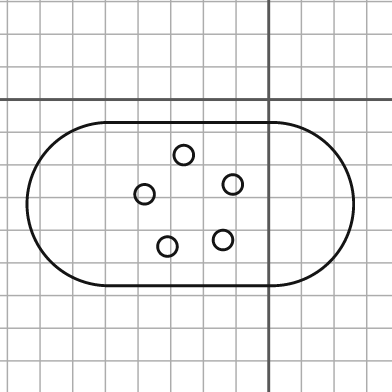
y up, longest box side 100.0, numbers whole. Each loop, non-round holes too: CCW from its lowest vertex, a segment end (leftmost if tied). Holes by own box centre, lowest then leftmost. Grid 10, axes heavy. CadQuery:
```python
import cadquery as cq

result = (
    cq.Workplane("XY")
    .moveTo(-49.0, -57.0)
    .lineTo(1.0, -57.0)
    .threePointArc((26.0, -32.0), (1.0, -7.0))
    .lineTo(-49.0, -7.0)
    .threePointArc((-74.0, -32.0), (-49.0, -57.0))
    .close()
    .moveTo(-31.0, -45.0)
    .circle(3.0)
    .moveTo(-14.0, -43.0)
    .circle(3.0)
    .moveTo(-38.0, -29.0)
    .circle(3.0)
    .moveTo(-11.0, -26.0)
    .circle(3.0)
    .moveTo(-26.0, -17.0)
    .circle(3.0)
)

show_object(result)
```